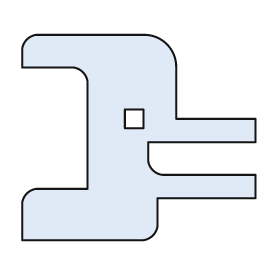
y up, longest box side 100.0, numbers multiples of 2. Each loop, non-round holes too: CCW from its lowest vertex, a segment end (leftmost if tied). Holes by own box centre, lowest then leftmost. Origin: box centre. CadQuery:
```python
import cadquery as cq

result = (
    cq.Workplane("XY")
    .moveTo(-50.0, -44.0)
    .lineTo(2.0, -44.0)
    .threePointArc((6.0, -42.0), (8.0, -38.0))
    .lineTo(8.0, -26.0)
    .lineTo(50.0, -26.0)
    .lineTo(50.0, -16.0)
    .lineTo(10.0, -16.0)
    .threePointArc((6.0, -14.0), (4.0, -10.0))
    .lineTo(4.0, -2.0)
    .lineTo(50.0, -2.0)
    .lineTo(50.0, 8.0)
    .lineTo(16.0, 8.0)
    .lineTo(16.0, 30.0)
    .threePointArc((12.0, 40.0), (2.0, 44.0))
    .lineTo(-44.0, 44.0)
    .threePointArc((-48.0, 42.0), (-50.0, 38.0))
    .lineTo(-50.0, 30.0)
    .lineTo(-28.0, 30.0)
    .threePointArc((-24.0, 28.0), (-22.0, 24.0))
    .lineTo(-22.0, -22.0)
    .lineTo(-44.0, -22.0)
    .threePointArc((-48.0, -24.0), (-50.0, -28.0))
    .close()
    .moveTo(-6.0, 4.0)
    .lineTo(2.0, 4.0)
    .lineTo(2.0, 12.0)
    .lineTo(-6.0, 12.0)
    .close()
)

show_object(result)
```